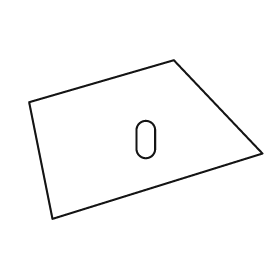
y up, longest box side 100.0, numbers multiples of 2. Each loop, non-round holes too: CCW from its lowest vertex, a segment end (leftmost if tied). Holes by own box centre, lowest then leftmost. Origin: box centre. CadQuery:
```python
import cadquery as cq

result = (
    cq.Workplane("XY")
    .moveTo(-40.0, -34.0)
    .lineTo(50.0, -6.0)
    .lineTo(12.0, 34.0)
    .lineTo(-50.0, 16.0)
    .close()
    .moveTo(-4.0, -4.0)
    .threePointArc((0.0, -8.0), (4.0, -4.0))
    .lineTo(4.0, 4.0)
    .threePointArc((0.0, 8.0), (-4.0, 4.0))
    .close()
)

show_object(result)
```